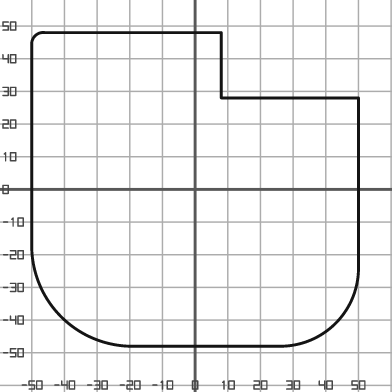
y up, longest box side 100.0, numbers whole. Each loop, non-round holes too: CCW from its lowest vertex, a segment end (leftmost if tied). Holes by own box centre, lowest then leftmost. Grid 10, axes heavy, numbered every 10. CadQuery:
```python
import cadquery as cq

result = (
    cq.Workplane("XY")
    .moveTo(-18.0, -48.0)
    .lineTo(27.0, -48.0)
    .threePointArc((43.0, -41.0), (50.0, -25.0))
    .lineTo(50.0, 28.0)
    .lineTo(8.0, 28.0)
    .lineTo(8.0, 48.0)
    .lineTo(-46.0, 48.0)
    .threePointArc((-49.0, 47.0), (-50.0, 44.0))
    .lineTo(-50.0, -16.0)
    .threePointArc((-41.0, -39.0), (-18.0, -48.0))
    .close()
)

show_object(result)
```